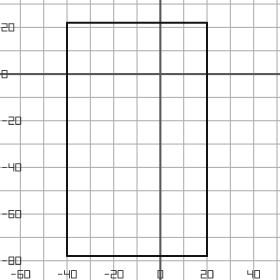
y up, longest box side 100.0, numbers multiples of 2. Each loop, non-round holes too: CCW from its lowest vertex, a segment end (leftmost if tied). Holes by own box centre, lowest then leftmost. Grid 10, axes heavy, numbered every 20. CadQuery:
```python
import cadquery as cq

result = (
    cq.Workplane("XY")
    .moveTo(-40.0, -78.0)
    .lineTo(20.0, -78.0)
    .lineTo(20.0, 22.0)
    .lineTo(-40.0, 22.0)
    .close()
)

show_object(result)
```